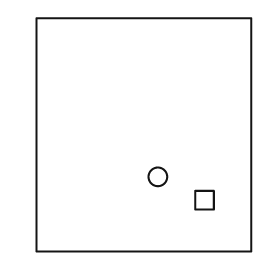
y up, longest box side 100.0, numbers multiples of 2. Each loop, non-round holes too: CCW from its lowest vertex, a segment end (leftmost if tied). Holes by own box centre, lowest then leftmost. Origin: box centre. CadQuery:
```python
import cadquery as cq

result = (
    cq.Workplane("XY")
    .moveTo(-46.0, -50.0)
    .lineTo(46.0, -50.0)
    .lineTo(46.0, 50.0)
    .lineTo(-46.0, 50.0)
    .close()
    .moveTo(22.0, -32.0)
    .lineTo(30.0, -32.0)
    .lineTo(30.0, -24.0)
    .lineTo(22.0, -24.0)
    .close()
    .moveTo(6.0, -18.0)
    .circle(4.0)
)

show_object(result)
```